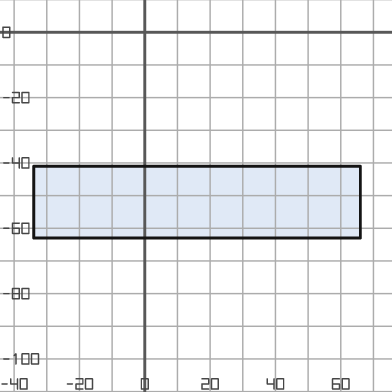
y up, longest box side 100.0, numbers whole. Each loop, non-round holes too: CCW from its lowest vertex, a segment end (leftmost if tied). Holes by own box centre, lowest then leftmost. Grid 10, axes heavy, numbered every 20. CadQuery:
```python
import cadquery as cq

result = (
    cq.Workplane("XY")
    .moveTo(-34.0, -63.0)
    .lineTo(66.0, -63.0)
    .lineTo(66.0, -41.0)
    .lineTo(-34.0, -41.0)
    .close()
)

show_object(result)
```